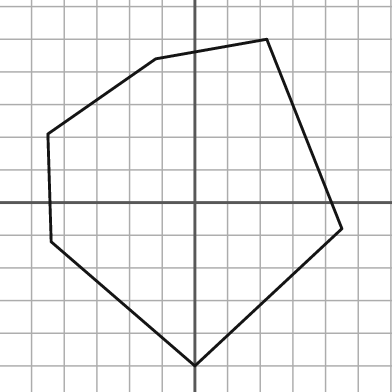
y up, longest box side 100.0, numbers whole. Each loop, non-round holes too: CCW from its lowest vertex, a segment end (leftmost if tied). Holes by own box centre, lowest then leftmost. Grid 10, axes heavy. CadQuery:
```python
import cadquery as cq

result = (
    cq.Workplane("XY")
    .moveTo(0.0, -50.0)
    .lineTo(45.0, -8.0)
    .lineTo(22.0, 50.0)
    .lineTo(-12.0, 44.0)
    .lineTo(-45.0, 21.0)
    .lineTo(-44.0, -12.0)
    .close()
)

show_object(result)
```